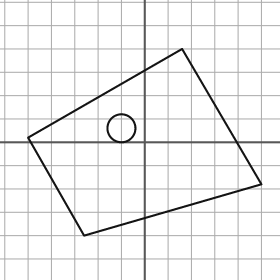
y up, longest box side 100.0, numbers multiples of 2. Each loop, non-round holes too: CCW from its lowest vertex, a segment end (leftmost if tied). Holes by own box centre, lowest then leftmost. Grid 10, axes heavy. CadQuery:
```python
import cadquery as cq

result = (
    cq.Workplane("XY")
    .moveTo(-26.0, -40.0)
    .lineTo(50.0, -18.0)
    .lineTo(16.0, 40.0)
    .lineTo(-50.0, 2.0)
    .close()
    .moveTo(-10.0, 6.0)
    .circle(6.0)
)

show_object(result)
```